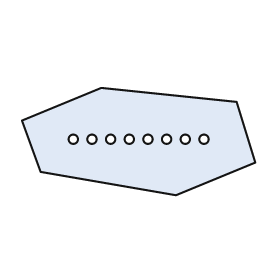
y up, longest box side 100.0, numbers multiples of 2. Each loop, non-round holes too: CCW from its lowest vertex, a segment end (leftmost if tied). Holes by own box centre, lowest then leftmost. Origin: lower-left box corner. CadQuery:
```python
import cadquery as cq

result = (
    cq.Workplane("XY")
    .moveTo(66.0, 0.0)
    .lineTo(100.0, 14.0)
    .lineTo(92.0, 40.0)
    .lineTo(34.0, 46.0)
    .lineTo(0.0, 32.0)
    .lineTo(8.0, 10.0)
    .close()
    .moveTo(22.0, 24.0)
    .circle(2.0)
    .moveTo(30.0, 24.0)
    .circle(2.0)
    .moveTo(38.0, 24.0)
    .circle(2.0)
    .moveTo(46.0, 24.0)
    .circle(2.0)
    .moveTo(54.0, 24.0)
    .circle(2.0)
    .moveTo(62.0, 24.0)
    .circle(2.0)
    .moveTo(70.0, 24.0)
    .circle(2.0)
    .moveTo(78.0, 24.0)
    .circle(2.0)
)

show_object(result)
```